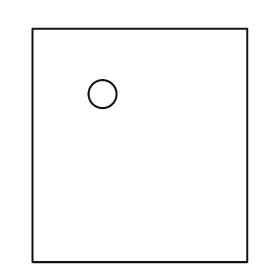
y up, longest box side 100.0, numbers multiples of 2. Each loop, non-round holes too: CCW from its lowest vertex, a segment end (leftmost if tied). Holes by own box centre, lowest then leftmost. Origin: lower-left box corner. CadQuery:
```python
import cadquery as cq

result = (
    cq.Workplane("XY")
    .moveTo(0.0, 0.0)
    .lineTo(92.0, 0.0)
    .lineTo(92.0, 100.0)
    .lineTo(0.0, 100.0)
    .close()
    .moveTo(30.0, 72.0)
    .circle(6.0)
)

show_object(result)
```